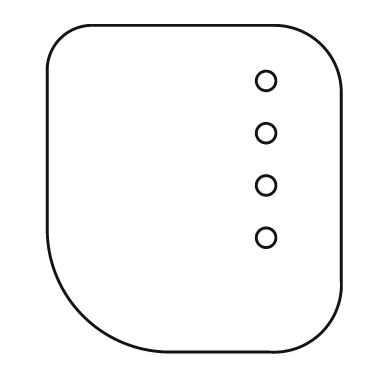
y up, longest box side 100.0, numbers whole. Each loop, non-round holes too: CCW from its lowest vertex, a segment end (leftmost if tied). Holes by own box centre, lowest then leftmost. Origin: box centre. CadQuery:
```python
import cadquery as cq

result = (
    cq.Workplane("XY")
    .moveTo(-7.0, -50.0)
    .lineTo(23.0, -50.0)
    .threePointArc((39.0, -44.0), (45.0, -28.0))
    .lineTo(45.0, 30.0)
    .threePointArc((39.0, 44.0), (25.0, 50.0))
    .lineTo(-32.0, 50.0)
    .threePointArc((-41.0, 46.0), (-45.0, 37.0))
    .lineTo(-45.0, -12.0)
    .threePointArc((-34.0, -39.0), (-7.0, -50.0))
    .close()
    .moveTo(22.0, -15.0)
    .circle(3.0)
    .moveTo(22.0, 1.0)
    .circle(3.0)
    .moveTo(22.0, 17.0)
    .circle(3.0)
    .moveTo(22.0, 33.0)
    .circle(3.0)
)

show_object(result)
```